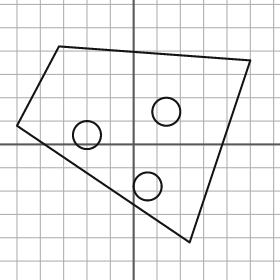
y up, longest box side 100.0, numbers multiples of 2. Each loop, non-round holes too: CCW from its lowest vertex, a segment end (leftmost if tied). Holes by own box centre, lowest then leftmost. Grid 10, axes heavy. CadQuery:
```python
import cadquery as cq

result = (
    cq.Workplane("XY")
    .moveTo(24.0, -42.0)
    .lineTo(50.0, 36.0)
    .lineTo(-32.0, 42.0)
    .lineTo(-50.0, 8.0)
    .close()
    .moveTo(6.0, -18.0)
    .circle(6.0)
    .moveTo(-20.0, 4.0)
    .circle(6.0)
    .moveTo(14.0, 14.0)
    .circle(6.0)
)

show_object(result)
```